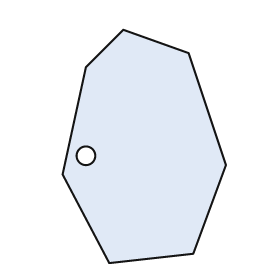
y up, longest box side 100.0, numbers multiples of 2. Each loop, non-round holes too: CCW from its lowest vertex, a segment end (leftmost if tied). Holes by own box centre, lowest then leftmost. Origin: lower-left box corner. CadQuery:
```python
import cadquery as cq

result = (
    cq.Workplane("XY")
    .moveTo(20.0, 0.0)
    .lineTo(56.0, 4.0)
    .lineTo(70.0, 42.0)
    .lineTo(54.0, 90.0)
    .lineTo(26.0, 100.0)
    .lineTo(10.0, 84.0)
    .lineTo(0.0, 38.0)
    .close()
    .moveTo(10.0, 46.0)
    .circle(4.0)
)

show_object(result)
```